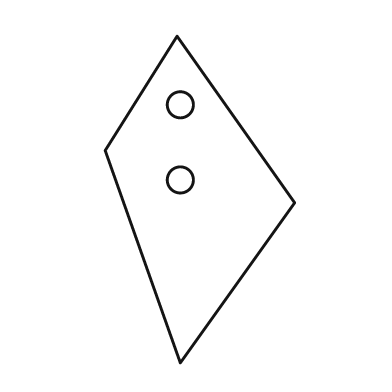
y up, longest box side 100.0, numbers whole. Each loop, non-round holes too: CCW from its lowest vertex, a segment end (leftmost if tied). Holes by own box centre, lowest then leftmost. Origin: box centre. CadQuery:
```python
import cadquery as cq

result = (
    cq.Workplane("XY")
    .moveTo(-6.0, -50.0)
    .lineTo(29.0, -1.0)
    .lineTo(-7.0, 50.0)
    .lineTo(-29.0, 15.0)
    .close()
    .moveTo(-6.0, 6.0)
    .circle(4.0)
    .moveTo(-6.0, 29.0)
    .circle(4.0)
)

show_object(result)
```